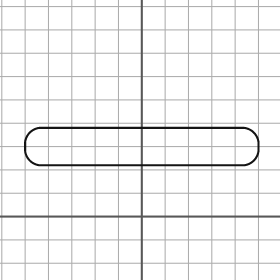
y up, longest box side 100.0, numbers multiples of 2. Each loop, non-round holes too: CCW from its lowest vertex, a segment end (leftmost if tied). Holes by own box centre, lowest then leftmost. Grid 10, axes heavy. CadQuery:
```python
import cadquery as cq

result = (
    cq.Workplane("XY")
    .moveTo(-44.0, 22.0)
    .lineTo(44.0, 22.0)
    .threePointArc((48.0, 24.0), (50.0, 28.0))
    .lineTo(50.0, 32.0)
    .threePointArc((48.0, 36.0), (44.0, 38.0))
    .lineTo(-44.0, 38.0)
    .threePointArc((-48.0, 36.0), (-50.0, 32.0))
    .lineTo(-50.0, 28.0)
    .threePointArc((-48.0, 24.0), (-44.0, 22.0))
    .close()
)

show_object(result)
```